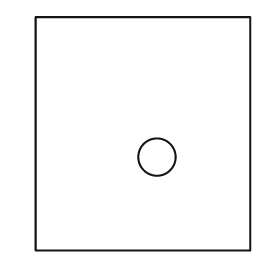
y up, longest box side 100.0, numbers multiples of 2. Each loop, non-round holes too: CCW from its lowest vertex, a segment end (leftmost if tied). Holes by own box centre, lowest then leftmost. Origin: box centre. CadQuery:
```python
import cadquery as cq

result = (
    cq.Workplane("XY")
    .moveTo(-46.0, -50.0)
    .lineTo(46.0, -50.0)
    .lineTo(46.0, 50.0)
    .lineTo(-46.0, 50.0)
    .close()
    .moveTo(6.0, -10.0)
    .circle(8.0)
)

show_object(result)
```